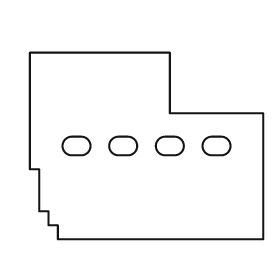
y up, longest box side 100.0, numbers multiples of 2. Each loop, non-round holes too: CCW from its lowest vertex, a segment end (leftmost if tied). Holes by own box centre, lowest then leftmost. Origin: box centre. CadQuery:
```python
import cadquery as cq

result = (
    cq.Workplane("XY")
    .moveTo(-38.0, -40.0)
    .lineTo(50.0, -40.0)
    .lineTo(50.0, 14.0)
    .lineTo(10.0, 14.0)
    .lineTo(10.0, 40.0)
    .lineTo(-50.0, 40.0)
    .lineTo(-50.0, -10.0)
    .lineTo(-46.0, -10.0)
    .lineTo(-46.0, -28.0)
    .lineTo(-42.0, -28.0)
    .lineTo(-42.0, -34.0)
    .lineTo(-38.0, -34.0)
    .close()
    .moveTo(-32.0, -4.0)
    .lineTo(-28.0, -4.0)
    .threePointArc((-24.0, 0.0), (-28.0, 4.0))
    .lineTo(-32.0, 4.0)
    .threePointArc((-36.0, 0.0), (-32.0, -4.0))
    .close()
    .moveTo(-12.0, -4.0)
    .lineTo(-8.0, -4.0)
    .threePointArc((-4.0, 0.0), (-8.0, 4.0))
    .lineTo(-12.0, 4.0)
    .threePointArc((-16.0, 0.0), (-12.0, -4.0))
    .close()
    .moveTo(8.0, -4.0)
    .lineTo(12.0, -4.0)
    .threePointArc((16.0, 0.0), (12.0, 4.0))
    .lineTo(8.0, 4.0)
    .threePointArc((4.0, 0.0), (8.0, -4.0))
    .close()
    .moveTo(28.0, -4.0)
    .lineTo(32.0, -4.0)
    .threePointArc((36.0, 0.0), (32.0, 4.0))
    .lineTo(28.0, 4.0)
    .threePointArc((24.0, 0.0), (28.0, -4.0))
    .close()
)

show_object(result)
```